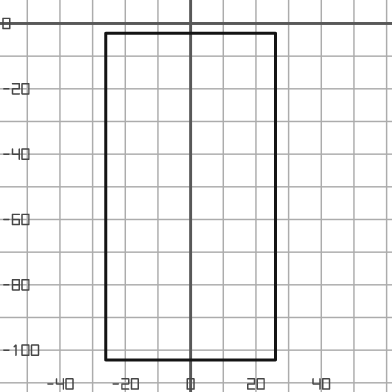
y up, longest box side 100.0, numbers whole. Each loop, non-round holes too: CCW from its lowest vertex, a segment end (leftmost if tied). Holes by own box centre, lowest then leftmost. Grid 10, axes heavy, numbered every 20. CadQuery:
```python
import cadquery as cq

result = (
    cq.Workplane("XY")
    .moveTo(-26.0, -103.0)
    .lineTo(26.0, -103.0)
    .lineTo(26.0, -3.0)
    .lineTo(-26.0, -3.0)
    .close()
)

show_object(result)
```